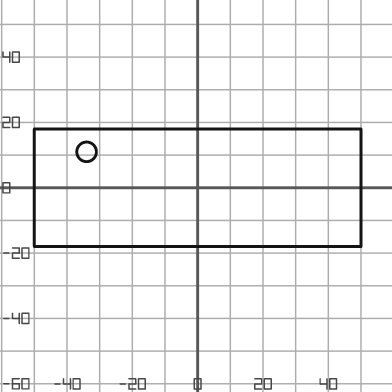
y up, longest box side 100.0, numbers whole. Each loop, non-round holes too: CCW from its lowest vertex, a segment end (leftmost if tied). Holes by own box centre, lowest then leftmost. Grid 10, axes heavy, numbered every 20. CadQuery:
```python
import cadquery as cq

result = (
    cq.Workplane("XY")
    .moveTo(-50.0, -18.0)
    .lineTo(50.0, -18.0)
    .lineTo(50.0, 18.0)
    .lineTo(-50.0, 18.0)
    .close()
    .moveTo(-34.0, 11.0)
    .circle(3.0)
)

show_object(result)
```